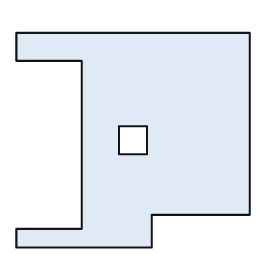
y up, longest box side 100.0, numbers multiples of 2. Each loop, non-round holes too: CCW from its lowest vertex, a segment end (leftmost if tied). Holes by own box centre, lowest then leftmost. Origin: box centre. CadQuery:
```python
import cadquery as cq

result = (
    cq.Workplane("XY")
    .moveTo(-50.0, -46.0)
    .lineTo(8.0, -46.0)
    .lineTo(8.0, -32.0)
    .lineTo(50.0, -32.0)
    .lineTo(50.0, 46.0)
    .lineTo(-50.0, 46.0)
    .lineTo(-50.0, 34.0)
    .lineTo(-22.0, 34.0)
    .lineTo(-22.0, -38.0)
    .lineTo(-50.0, -38.0)
    .close()
    .moveTo(-6.0, -6.0)
    .lineTo(6.0, -6.0)
    .lineTo(6.0, 6.0)
    .lineTo(-6.0, 6.0)
    .close()
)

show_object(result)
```